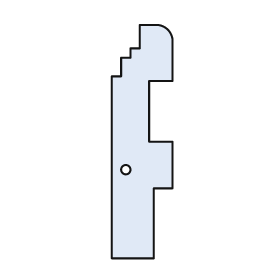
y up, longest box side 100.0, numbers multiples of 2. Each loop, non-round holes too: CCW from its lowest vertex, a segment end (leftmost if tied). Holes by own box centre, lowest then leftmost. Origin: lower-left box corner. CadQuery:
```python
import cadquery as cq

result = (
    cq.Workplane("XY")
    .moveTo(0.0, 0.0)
    .lineTo(18.0, 0.0)
    .lineTo(18.0, 30.0)
    .lineTo(26.0, 30.0)
    .lineTo(26.0, 50.0)
    .lineTo(16.0, 50.0)
    .lineTo(16.0, 76.0)
    .lineTo(26.0, 76.0)
    .lineTo(26.0, 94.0)
    .threePointArc((24.0, 98.0), (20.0, 100.0))
    .lineTo(12.0, 100.0)
    .lineTo(12.0, 90.0)
    .lineTo(8.0, 90.0)
    .lineTo(8.0, 86.0)
    .lineTo(4.0, 86.0)
    .lineTo(4.0, 78.0)
    .lineTo(0.0, 78.0)
    .close()
    .moveTo(6.0, 38.0)
    .circle(2.0)
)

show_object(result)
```